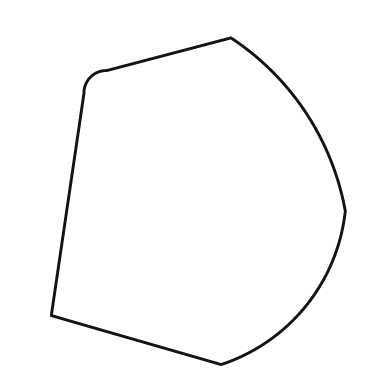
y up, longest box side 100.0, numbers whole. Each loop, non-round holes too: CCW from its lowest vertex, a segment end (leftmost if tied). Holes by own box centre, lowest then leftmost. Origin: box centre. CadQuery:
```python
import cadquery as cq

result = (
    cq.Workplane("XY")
    .moveTo(7.0, -50.0)
    .threePointArc((33.0, -32.0), (45.0, -3.0))
    .threePointArc((33.0, 27.0), (10.0, 50.0))
    .lineTo(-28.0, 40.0)
    .threePointArc((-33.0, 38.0), (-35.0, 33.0))
    .lineTo(-45.0, -35.0)
    .close()
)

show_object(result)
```